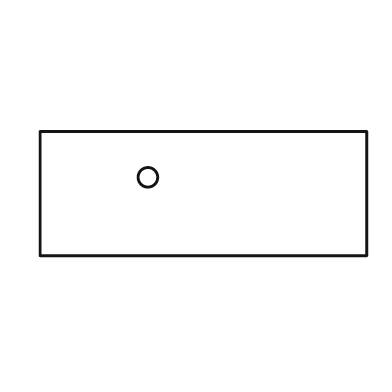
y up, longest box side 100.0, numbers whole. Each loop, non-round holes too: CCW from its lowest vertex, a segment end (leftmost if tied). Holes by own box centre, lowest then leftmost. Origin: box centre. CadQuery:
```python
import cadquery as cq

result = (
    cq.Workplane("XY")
    .moveTo(-50.0, -19.0)
    .lineTo(50.0, -19.0)
    .lineTo(50.0, 19.0)
    .lineTo(-50.0, 19.0)
    .close()
    .moveTo(-17.0, 5.0)
    .circle(3.0)
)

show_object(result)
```